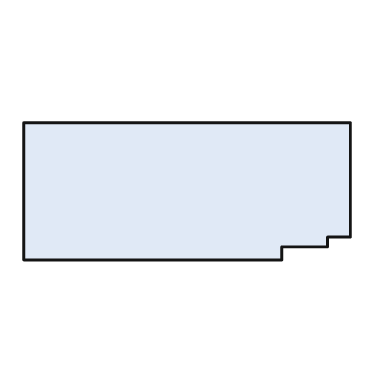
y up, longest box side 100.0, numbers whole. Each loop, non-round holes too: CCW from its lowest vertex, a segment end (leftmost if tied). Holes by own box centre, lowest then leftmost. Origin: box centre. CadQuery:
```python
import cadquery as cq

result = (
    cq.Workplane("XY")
    .moveTo(-50.0, -21.0)
    .lineTo(29.0, -21.0)
    .lineTo(29.0, -17.0)
    .lineTo(43.0, -17.0)
    .lineTo(43.0, -14.0)
    .lineTo(50.0, -14.0)
    .lineTo(50.0, 21.0)
    .lineTo(-50.0, 21.0)
    .close()
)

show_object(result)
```